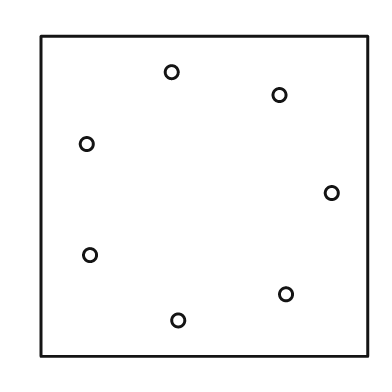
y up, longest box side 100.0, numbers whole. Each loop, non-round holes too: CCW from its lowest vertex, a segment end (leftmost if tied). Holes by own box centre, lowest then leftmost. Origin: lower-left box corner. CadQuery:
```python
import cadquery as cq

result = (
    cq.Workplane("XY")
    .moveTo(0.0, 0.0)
    .lineTo(100.0, 0.0)
    .lineTo(100.0, 98.0)
    .lineTo(0.0, 98.0)
    .close()
    .moveTo(42.0, 11.0)
    .circle(2.0)
    .moveTo(75.0, 19.0)
    .circle(2.0)
    .moveTo(15.0, 31.0)
    .circle(2.0)
    .moveTo(89.0, 50.0)
    .circle(2.0)
    .moveTo(14.0, 65.0)
    .circle(2.0)
    .moveTo(73.0, 80.0)
    .circle(2.0)
    .moveTo(40.0, 87.0)
    .circle(2.0)
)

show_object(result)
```